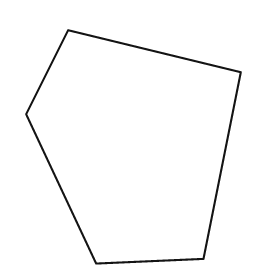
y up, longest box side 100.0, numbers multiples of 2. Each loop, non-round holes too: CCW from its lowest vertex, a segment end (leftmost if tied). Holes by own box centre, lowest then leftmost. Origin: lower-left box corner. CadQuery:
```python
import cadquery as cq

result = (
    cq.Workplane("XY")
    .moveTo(30.0, 0.0)
    .lineTo(76.0, 2.0)
    .lineTo(92.0, 82.0)
    .lineTo(18.0, 100.0)
    .lineTo(0.0, 64.0)
    .close()
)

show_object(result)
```